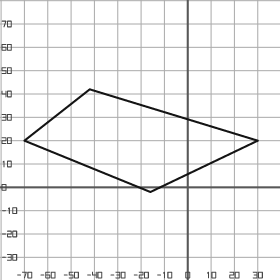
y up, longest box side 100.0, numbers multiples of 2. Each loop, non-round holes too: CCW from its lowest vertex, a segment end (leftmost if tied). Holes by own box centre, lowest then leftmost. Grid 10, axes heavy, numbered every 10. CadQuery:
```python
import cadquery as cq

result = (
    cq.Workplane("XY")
    .moveTo(-16.0, -2.0)
    .lineTo(30.0, 20.0)
    .lineTo(-42.0, 42.0)
    .lineTo(-70.0, 20.0)
    .close()
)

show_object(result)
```